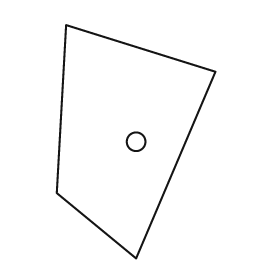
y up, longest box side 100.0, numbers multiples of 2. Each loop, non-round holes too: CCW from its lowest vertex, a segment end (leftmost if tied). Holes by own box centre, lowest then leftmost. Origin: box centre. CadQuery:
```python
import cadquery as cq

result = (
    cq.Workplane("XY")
    .moveTo(0.0, -50.0)
    .lineTo(34.0, 30.0)
    .lineTo(-30.0, 50.0)
    .lineTo(-34.0, -22.0)
    .close()
    .moveTo(0.0, 0.0)
    .circle(4.0)
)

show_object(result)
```